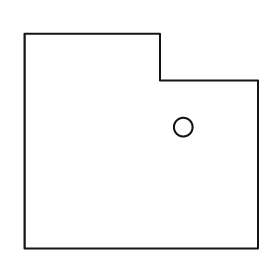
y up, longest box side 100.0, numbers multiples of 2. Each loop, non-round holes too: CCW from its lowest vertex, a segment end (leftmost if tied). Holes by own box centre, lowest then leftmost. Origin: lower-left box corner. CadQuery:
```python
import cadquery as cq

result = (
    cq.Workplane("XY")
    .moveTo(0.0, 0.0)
    .lineTo(100.0, 0.0)
    .lineTo(100.0, 72.0)
    .lineTo(58.0, 72.0)
    .lineTo(58.0, 92.0)
    .lineTo(0.0, 92.0)
    .close()
    .moveTo(68.0, 52.0)
    .circle(4.0)
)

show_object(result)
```